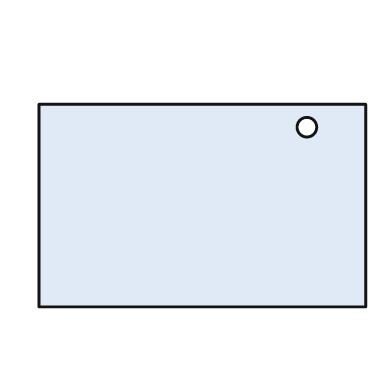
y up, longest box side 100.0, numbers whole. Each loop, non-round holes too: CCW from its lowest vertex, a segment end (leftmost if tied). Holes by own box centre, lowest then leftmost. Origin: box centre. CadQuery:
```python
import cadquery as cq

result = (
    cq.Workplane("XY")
    .moveTo(-50.0, -31.0)
    .lineTo(50.0, -31.0)
    .lineTo(50.0, 31.0)
    .lineTo(-50.0, 31.0)
    .close()
    .moveTo(32.0, 24.0)
    .circle(3.0)
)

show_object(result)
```